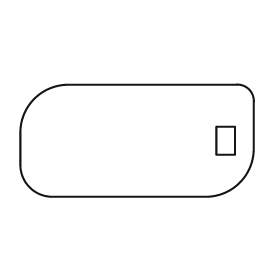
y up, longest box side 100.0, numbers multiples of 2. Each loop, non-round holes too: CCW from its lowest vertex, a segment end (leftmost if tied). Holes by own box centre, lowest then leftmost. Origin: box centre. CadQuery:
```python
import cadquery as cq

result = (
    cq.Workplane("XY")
    .moveTo(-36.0, -24.0)
    .lineTo(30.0, -24.0)
    .threePointArc((44.0, -18.0), (50.0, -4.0))
    .lineTo(50.0, 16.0)
    .threePointArc((48.0, 22.0), (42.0, 24.0))
    .lineTo(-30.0, 24.0)
    .threePointArc((-44.0, 18.0), (-50.0, 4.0))
    .lineTo(-50.0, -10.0)
    .threePointArc((-46.0, -20.0), (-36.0, -24.0))
    .close()
    .moveTo(34.0, -6.0)
    .lineTo(42.0, -6.0)
    .lineTo(42.0, 6.0)
    .lineTo(34.0, 6.0)
    .close()
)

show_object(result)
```